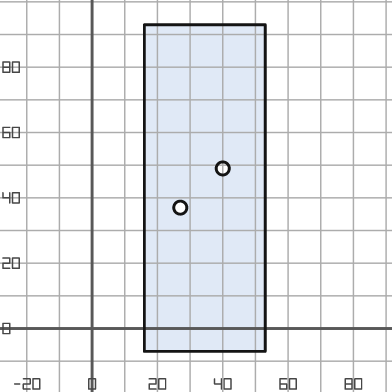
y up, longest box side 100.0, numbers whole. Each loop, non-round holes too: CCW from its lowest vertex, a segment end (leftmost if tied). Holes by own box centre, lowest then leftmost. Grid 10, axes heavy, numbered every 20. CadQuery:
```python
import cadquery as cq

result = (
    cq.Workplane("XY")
    .moveTo(16.0, -7.0)
    .lineTo(53.0, -7.0)
    .lineTo(53.0, 93.0)
    .lineTo(16.0, 93.0)
    .close()
    .moveTo(27.0, 37.0)
    .circle(2.0)
    .moveTo(40.0, 49.0)
    .circle(2.0)
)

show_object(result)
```